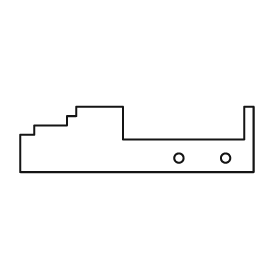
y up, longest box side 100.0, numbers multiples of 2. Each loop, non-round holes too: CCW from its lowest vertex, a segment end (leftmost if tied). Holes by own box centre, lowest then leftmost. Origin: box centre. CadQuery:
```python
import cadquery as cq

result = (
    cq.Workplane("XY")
    .moveTo(-50.0, -14.0)
    .lineTo(50.0, -14.0)
    .lineTo(50.0, 14.0)
    .lineTo(46.0, 14.0)
    .lineTo(46.0, 0.0)
    .lineTo(-6.0, 0.0)
    .lineTo(-6.0, 14.0)
    .lineTo(-26.0, 14.0)
    .lineTo(-26.0, 10.0)
    .lineTo(-30.0, 10.0)
    .lineTo(-30.0, 6.0)
    .lineTo(-44.0, 6.0)
    .lineTo(-44.0, 2.0)
    .lineTo(-50.0, 2.0)
    .close()
    .moveTo(18.0, -8.0)
    .circle(2.0)
    .moveTo(38.0, -8.0)
    .circle(2.0)
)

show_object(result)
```